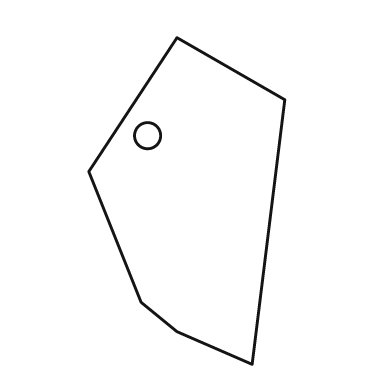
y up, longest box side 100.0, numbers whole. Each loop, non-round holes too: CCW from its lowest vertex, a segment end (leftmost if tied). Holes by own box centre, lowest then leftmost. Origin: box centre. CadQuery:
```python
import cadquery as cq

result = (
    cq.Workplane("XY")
    .moveTo(20.0, -50.0)
    .lineTo(30.0, 31.0)
    .lineTo(-3.0, 50.0)
    .lineTo(-30.0, 9.0)
    .lineTo(-14.0, -31.0)
    .lineTo(-3.0, -40.0)
    .close()
    .moveTo(-12.0, 20.0)
    .circle(4.0)
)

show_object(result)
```